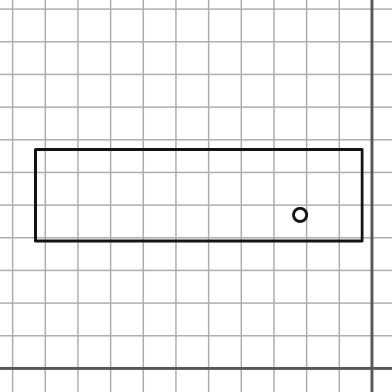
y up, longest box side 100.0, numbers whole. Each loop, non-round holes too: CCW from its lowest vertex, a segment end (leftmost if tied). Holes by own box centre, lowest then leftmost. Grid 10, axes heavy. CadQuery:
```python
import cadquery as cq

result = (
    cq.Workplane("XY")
    .moveTo(-103.0, 39.0)
    .lineTo(-3.0, 39.0)
    .lineTo(-3.0, 67.0)
    .lineTo(-103.0, 67.0)
    .close()
    .moveTo(-22.0, 47.0)
    .circle(2.0)
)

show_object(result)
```